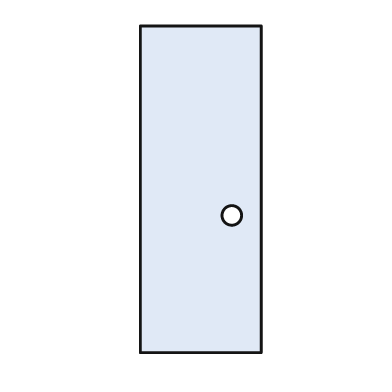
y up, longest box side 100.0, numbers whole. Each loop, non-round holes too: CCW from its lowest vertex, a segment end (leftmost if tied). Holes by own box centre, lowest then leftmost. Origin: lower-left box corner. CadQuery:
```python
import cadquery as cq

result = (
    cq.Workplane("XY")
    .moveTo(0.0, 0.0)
    .lineTo(37.0, 0.0)
    .lineTo(37.0, 100.0)
    .lineTo(0.0, 100.0)
    .close()
    .moveTo(28.0, 42.0)
    .circle(3.0)
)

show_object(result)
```